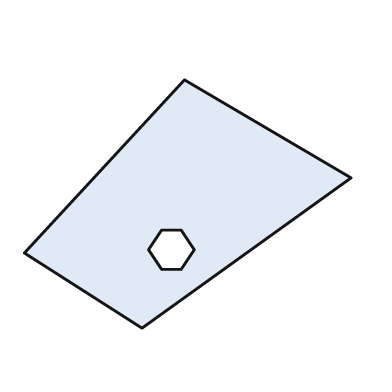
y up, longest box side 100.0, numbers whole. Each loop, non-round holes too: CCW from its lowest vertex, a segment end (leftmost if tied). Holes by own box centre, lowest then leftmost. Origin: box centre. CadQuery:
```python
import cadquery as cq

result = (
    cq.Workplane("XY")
    .moveTo(-14.0, -38.0)
    .lineTo(50.0, 8.0)
    .lineTo(-1.0, 38.0)
    .lineTo(-50.0, -15.0)
    .close()
    .moveTo(-8.0, -20.0)
    .lineTo(-2.0, -20.0)
    .lineTo(2.0, -14.0)
    .lineTo(-2.0, -8.0)
    .lineTo(-8.0, -8.0)
    .lineTo(-12.0, -14.0)
    .close()
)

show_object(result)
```